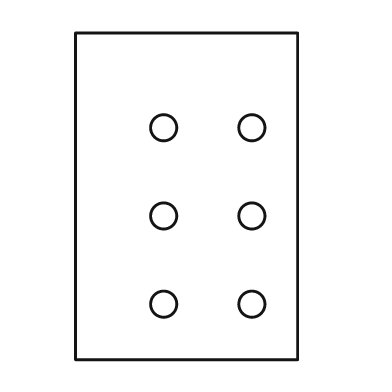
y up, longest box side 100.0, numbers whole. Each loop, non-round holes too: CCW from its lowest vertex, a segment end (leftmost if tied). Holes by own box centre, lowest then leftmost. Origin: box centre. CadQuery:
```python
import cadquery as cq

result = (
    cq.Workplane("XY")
    .moveTo(-34.0, -50.0)
    .lineTo(34.0, -50.0)
    .lineTo(34.0, 50.0)
    .lineTo(-34.0, 50.0)
    .close()
    .moveTo(-7.0, -33.0)
    .circle(4.0)
    .moveTo(20.0, -33.0)
    .circle(4.0)
    .moveTo(-7.0, -6.0)
    .circle(4.0)
    .moveTo(20.0, -6.0)
    .circle(4.0)
    .moveTo(-7.0, 21.0)
    .circle(4.0)
    .moveTo(20.0, 21.0)
    .circle(4.0)
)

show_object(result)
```